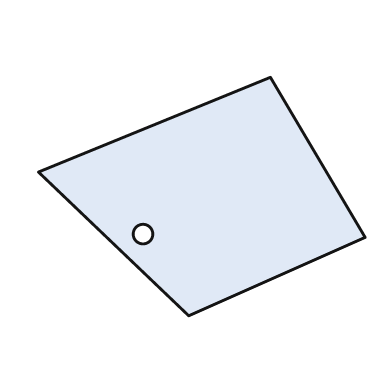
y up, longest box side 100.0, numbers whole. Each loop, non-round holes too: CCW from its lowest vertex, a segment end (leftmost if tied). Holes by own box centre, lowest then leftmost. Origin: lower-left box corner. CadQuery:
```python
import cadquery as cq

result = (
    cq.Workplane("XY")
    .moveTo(46.0, 0.0)
    .lineTo(100.0, 24.0)
    .lineTo(71.0, 73.0)
    .lineTo(0.0, 44.0)
    .close()
    .moveTo(32.0, 25.0)
    .circle(3.0)
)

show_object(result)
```